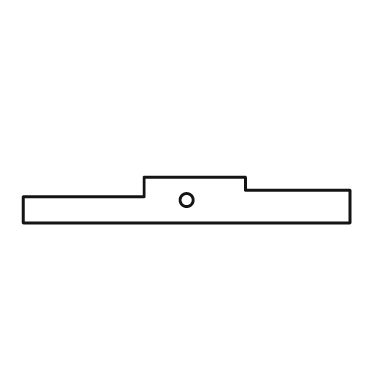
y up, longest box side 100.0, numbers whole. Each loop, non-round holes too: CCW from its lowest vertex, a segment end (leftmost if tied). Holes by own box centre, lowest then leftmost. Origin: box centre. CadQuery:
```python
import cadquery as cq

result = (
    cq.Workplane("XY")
    .moveTo(-50.0, -7.0)
    .lineTo(50.0, -7.0)
    .lineTo(50.0, 3.0)
    .lineTo(18.0, 3.0)
    .lineTo(18.0, 7.0)
    .lineTo(-13.0, 7.0)
    .lineTo(-13.0, 1.0)
    .lineTo(-50.0, 1.0)
    .close()
    .moveTo(0.0, 0.0)
    .circle(2.0)
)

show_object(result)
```